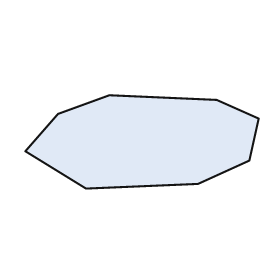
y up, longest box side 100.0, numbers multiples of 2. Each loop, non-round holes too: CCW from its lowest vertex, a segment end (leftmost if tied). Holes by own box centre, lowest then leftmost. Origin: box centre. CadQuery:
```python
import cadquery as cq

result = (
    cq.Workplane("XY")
    .moveTo(-24.0, -20.0)
    .lineTo(24.0, -18.0)
    .lineTo(46.0, -8.0)
    .lineTo(50.0, 10.0)
    .lineTo(32.0, 18.0)
    .lineTo(-14.0, 20.0)
    .lineTo(-36.0, 12.0)
    .lineTo(-50.0, -4.0)
    .close()
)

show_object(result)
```